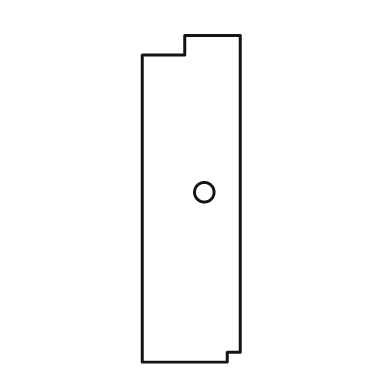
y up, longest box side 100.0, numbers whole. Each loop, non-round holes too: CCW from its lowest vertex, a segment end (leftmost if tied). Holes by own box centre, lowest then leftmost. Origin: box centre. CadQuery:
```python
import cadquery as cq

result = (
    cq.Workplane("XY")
    .moveTo(-15.0, -50.0)
    .lineTo(11.0, -50.0)
    .lineTo(11.0, -47.0)
    .lineTo(15.0, -47.0)
    .lineTo(15.0, 50.0)
    .lineTo(-2.0, 50.0)
    .lineTo(-2.0, 44.0)
    .lineTo(-15.0, 44.0)
    .close()
    .moveTo(4.0, 2.0)
    .circle(3.0)
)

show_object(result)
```